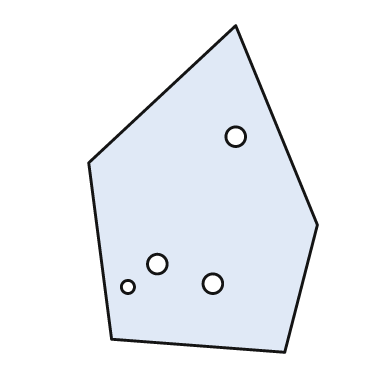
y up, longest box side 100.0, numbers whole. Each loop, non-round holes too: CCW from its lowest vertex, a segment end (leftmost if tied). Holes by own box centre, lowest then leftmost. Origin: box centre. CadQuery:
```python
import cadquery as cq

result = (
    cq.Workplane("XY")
    .moveTo(25.0, -50.0)
    .lineTo(35.0, -11.0)
    .lineTo(10.0, 50.0)
    .lineTo(-35.0, 8.0)
    .lineTo(-28.0, -46.0)
    .close()
    .moveTo(-23.0, -30.0)
    .circle(2.0)
    .moveTo(3.0, -29.0)
    .circle(3.0)
    .moveTo(-14.0, -23.0)
    .circle(3.0)
    .moveTo(10.0, 16.0)
    .circle(3.0)
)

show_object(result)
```